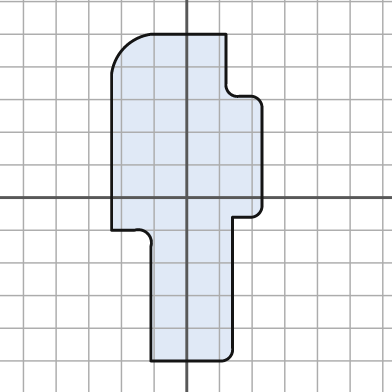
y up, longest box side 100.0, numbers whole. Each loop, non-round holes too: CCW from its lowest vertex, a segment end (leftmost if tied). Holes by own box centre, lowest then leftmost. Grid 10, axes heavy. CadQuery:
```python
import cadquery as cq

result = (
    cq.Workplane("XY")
    .moveTo(-11.0, -50.0)
    .lineTo(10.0, -50.0)
    .threePointArc((13.0, -49.0), (14.0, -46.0))
    .lineTo(14.0, -6.0)
    .lineTo(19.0, -6.0)
    .threePointArc((22.0, -5.0), (23.0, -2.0))
    .lineTo(23.0, 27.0)
    .threePointArc((22.0, 30.0), (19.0, 31.0))
    .lineTo(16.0, 31.0)
    .threePointArc((13.0, 32.0), (12.0, 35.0))
    .lineTo(12.0, 50.0)
    .lineTo(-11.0, 50.0)
    .threePointArc((-19.0, 46.0), (-23.0, 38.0))
    .lineTo(-23.0, -10.0)
    .lineTo(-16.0, -10.0)
    .threePointArc((-12.0, -11.0), (-11.0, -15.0))
    .close()
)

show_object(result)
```